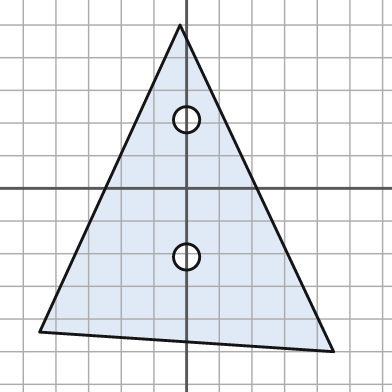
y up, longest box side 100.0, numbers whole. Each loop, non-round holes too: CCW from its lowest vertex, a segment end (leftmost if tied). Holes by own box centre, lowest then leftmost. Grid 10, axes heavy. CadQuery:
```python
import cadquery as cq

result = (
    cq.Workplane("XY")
    .moveTo(45.0, -50.0)
    .lineTo(-2.0, 50.0)
    .lineTo(-45.0, -44.0)
    .close()
    .moveTo(0.0, -21.0)
    .circle(4.0)
    .moveTo(0.0, 21.0)
    .circle(4.0)
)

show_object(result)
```